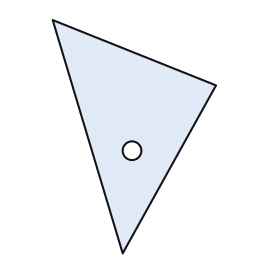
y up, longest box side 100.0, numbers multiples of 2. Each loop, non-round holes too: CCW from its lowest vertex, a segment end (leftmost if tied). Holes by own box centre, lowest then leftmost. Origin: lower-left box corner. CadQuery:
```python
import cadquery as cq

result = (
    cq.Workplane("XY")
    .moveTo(30.0, 0.0)
    .lineTo(70.0, 72.0)
    .lineTo(0.0, 100.0)
    .close()
    .moveTo(34.0, 44.0)
    .circle(4.0)
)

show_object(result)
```